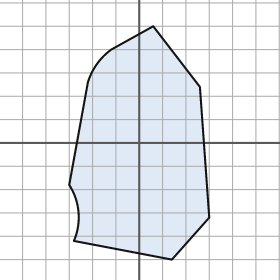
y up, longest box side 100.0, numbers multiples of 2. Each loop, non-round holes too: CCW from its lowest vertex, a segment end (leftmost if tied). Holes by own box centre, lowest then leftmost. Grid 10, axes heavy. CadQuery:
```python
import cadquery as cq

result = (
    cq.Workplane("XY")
    .moveTo(14.0, -50.0)
    .lineTo(30.0, -32.0)
    .lineTo(26.0, 24.0)
    .lineTo(6.0, 50.0)
    .lineTo(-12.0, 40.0)
    .threePointArc((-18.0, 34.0), (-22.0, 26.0))
    .lineTo(-30.0, -18.0)
    .threePointArc((-26.0, -30.0), (-28.0, -42.0))
    .close()
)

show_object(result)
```